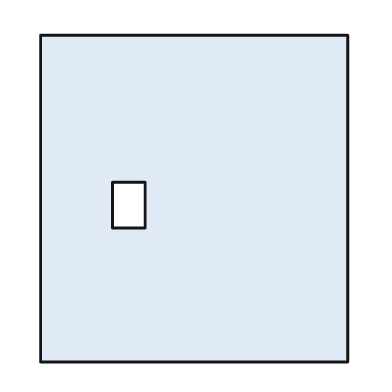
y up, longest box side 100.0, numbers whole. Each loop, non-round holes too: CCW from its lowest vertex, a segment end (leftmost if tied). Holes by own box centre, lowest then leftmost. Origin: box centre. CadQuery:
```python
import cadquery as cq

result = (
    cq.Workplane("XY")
    .moveTo(-47.0, -50.0)
    .lineTo(47.0, -50.0)
    .lineTo(47.0, 50.0)
    .lineTo(-47.0, 50.0)
    .close()
    .moveTo(-25.0, -9.0)
    .lineTo(-15.0, -9.0)
    .lineTo(-15.0, 5.0)
    .lineTo(-25.0, 5.0)
    .close()
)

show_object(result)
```